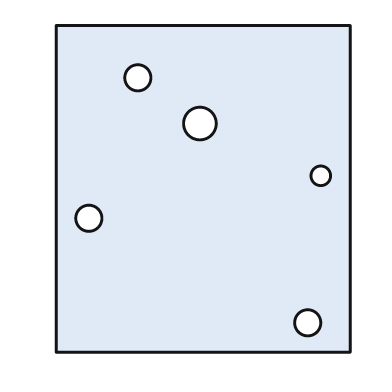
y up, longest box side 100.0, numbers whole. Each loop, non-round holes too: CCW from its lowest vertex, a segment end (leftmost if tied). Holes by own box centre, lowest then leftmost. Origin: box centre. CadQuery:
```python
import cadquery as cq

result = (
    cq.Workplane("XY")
    .moveTo(-45.0, -50.0)
    .lineTo(45.0, -50.0)
    .lineTo(45.0, 50.0)
    .lineTo(-45.0, 50.0)
    .close()
    .moveTo(32.0, -41.0)
    .circle(4.0)
    .moveTo(-35.0, -9.0)
    .circle(4.0)
    .moveTo(36.0, 4.0)
    .circle(3.0)
    .moveTo(-1.0, 20.0)
    .circle(5.0)
    .moveTo(-20.0, 34.0)
    .circle(4.0)
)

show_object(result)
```